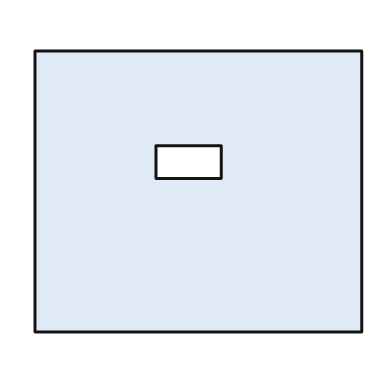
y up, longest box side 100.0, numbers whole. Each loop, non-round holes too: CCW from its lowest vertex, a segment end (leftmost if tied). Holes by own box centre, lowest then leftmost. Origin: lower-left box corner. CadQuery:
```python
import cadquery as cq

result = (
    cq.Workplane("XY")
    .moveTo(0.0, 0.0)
    .lineTo(100.0, 0.0)
    .lineTo(100.0, 86.0)
    .lineTo(0.0, 86.0)
    .close()
    .moveTo(37.0, 47.0)
    .lineTo(57.0, 47.0)
    .lineTo(57.0, 57.0)
    .lineTo(37.0, 57.0)
    .close()
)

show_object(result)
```